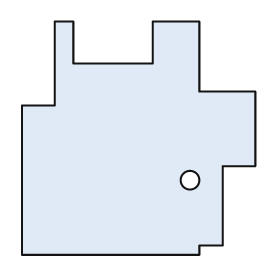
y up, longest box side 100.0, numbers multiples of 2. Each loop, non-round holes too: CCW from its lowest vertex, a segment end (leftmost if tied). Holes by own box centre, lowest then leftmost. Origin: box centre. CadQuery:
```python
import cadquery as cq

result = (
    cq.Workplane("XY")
    .moveTo(-50.0, -50.0)
    .lineTo(26.0, -50.0)
    .lineTo(26.0, -46.0)
    .lineTo(36.0, -46.0)
    .lineTo(36.0, -12.0)
    .lineTo(50.0, -12.0)
    .lineTo(50.0, 20.0)
    .lineTo(26.0, 20.0)
    .lineTo(26.0, 50.0)
    .lineTo(6.0, 50.0)
    .lineTo(6.0, 32.0)
    .lineTo(-28.0, 32.0)
    .lineTo(-28.0, 50.0)
    .lineTo(-36.0, 50.0)
    .lineTo(-36.0, 14.0)
    .lineTo(-50.0, 14.0)
    .close()
    .moveTo(22.0, -18.0)
    .circle(4.0)
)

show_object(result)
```